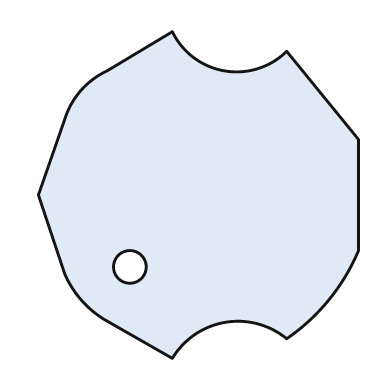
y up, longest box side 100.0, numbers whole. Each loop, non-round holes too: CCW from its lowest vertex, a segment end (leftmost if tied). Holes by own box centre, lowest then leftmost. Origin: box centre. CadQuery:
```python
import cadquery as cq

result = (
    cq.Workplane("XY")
    .moveTo(-8.0, -50.0)
    .threePointArc((8.0, -39.0), (27.0, -44.0))
    .threePointArc((40.0, -32.0), (49.0, -17.0))
    .lineTo(49.0, 17.0)
    .lineTo(27.0, 44.0)
    .threePointArc((8.0, 38.0), (-8.0, 50.0))
    .lineTo(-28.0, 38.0)
    .threePointArc((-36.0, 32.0), (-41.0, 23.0))
    .lineTo(-49.0, 0.0)
    .lineTo(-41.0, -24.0)
    .threePointArc((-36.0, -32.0), (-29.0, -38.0))
    .close()
    .moveTo(-21.0, -22.0)
    .circle(5.0)
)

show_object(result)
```